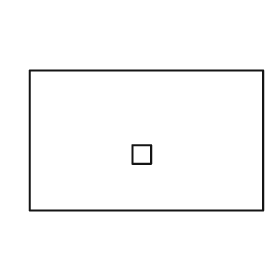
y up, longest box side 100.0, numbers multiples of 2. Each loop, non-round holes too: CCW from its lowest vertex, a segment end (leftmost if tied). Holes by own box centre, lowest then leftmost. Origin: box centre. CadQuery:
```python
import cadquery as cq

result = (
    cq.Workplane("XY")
    .moveTo(-50.0, -30.0)
    .lineTo(50.0, -30.0)
    .lineTo(50.0, 30.0)
    .lineTo(-50.0, 30.0)
    .close()
    .moveTo(-6.0, -10.0)
    .lineTo(2.0, -10.0)
    .lineTo(2.0, -2.0)
    .lineTo(-6.0, -2.0)
    .close()
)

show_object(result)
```